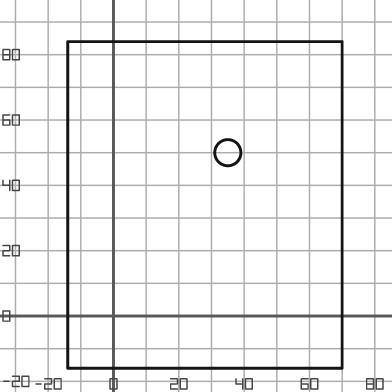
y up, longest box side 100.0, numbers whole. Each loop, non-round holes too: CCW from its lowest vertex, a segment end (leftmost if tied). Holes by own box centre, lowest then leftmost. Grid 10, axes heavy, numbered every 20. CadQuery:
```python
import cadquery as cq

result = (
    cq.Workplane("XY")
    .moveTo(-14.0, -16.0)
    .lineTo(70.0, -16.0)
    .lineTo(70.0, 84.0)
    .lineTo(-14.0, 84.0)
    .close()
    .moveTo(35.0, 50.0)
    .circle(4.0)
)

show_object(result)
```